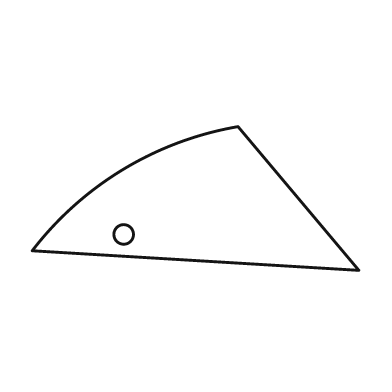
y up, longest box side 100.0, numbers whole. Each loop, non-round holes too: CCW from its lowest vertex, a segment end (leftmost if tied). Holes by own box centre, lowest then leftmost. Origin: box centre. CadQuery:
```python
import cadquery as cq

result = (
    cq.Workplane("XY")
    .moveTo(50.0, -22.0)
    .lineTo(13.0, 22.0)
    .threePointArc((-22.0, 9.0), (-50.0, -16.0))
    .close()
    .moveTo(-22.0, -11.0)
    .circle(3.0)
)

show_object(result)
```